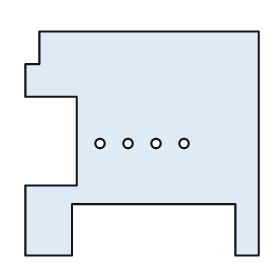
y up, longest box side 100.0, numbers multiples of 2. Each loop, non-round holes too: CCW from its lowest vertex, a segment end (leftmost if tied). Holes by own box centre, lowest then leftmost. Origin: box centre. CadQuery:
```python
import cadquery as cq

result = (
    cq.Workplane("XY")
    .moveTo(-50.0, -48.0)
    .lineTo(-30.0, -48.0)
    .lineTo(-30.0, -26.0)
    .lineTo(40.0, -26.0)
    .lineTo(40.0, -48.0)
    .lineTo(50.0, -48.0)
    .lineTo(50.0, 48.0)
    .lineTo(-44.0, 48.0)
    .lineTo(-44.0, 34.0)
    .lineTo(-50.0, 34.0)
    .lineTo(-50.0, 20.0)
    .lineTo(-28.0, 20.0)
    .lineTo(-28.0, -18.0)
    .lineTo(-50.0, -18.0)
    .close()
    .moveTo(-18.0, 0.0)
    .circle(2.0)
    .moveTo(-6.0, 0.0)
    .circle(2.0)
    .moveTo(6.0, 0.0)
    .circle(2.0)
    .moveTo(18.0, 0.0)
    .circle(2.0)
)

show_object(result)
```